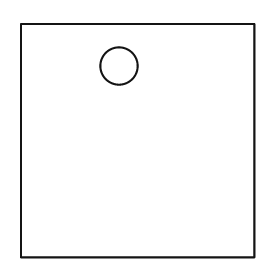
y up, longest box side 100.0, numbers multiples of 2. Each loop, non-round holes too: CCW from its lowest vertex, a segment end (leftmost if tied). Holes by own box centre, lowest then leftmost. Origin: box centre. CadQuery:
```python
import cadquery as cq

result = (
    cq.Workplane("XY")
    .moveTo(-50.0, -50.0)
    .lineTo(50.0, -50.0)
    .lineTo(50.0, 50.0)
    .lineTo(-50.0, 50.0)
    .close()
    .moveTo(-8.0, 32.0)
    .circle(8.0)
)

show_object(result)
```